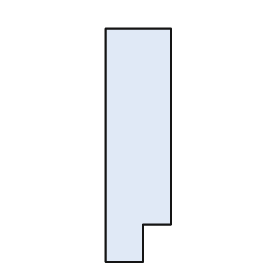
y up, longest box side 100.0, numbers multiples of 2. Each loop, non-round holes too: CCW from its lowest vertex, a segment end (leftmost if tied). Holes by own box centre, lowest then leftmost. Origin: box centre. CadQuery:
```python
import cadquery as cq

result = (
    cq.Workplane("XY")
    .moveTo(-14.0, -50.0)
    .lineTo(2.0, -50.0)
    .lineTo(2.0, -34.0)
    .lineTo(14.0, -34.0)
    .lineTo(14.0, 50.0)
    .lineTo(-14.0, 50.0)
    .close()
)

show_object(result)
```